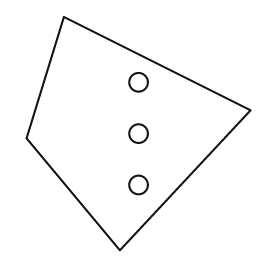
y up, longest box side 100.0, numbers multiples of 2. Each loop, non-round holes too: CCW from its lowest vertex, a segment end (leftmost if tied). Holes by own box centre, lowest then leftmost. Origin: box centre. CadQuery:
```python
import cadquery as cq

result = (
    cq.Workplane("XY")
    .moveTo(-8.0, -50.0)
    .lineTo(48.0, 10.0)
    .lineTo(-32.0, 50.0)
    .lineTo(-48.0, -2.0)
    .close()
    .moveTo(0.0, -22.0)
    .circle(4.0)
    .moveTo(0.0, 0.0)
    .circle(4.0)
    .moveTo(0.0, 22.0)
    .circle(4.0)
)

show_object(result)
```